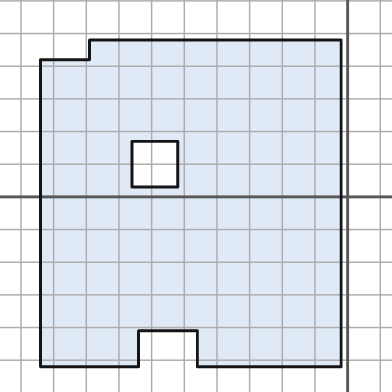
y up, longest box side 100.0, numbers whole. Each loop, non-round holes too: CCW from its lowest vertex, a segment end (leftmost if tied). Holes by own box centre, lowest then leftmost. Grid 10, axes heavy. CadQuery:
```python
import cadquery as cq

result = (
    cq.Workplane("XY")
    .moveTo(-94.0, -52.0)
    .lineTo(-64.0, -52.0)
    .lineTo(-64.0, -41.0)
    .lineTo(-46.0, -41.0)
    .lineTo(-46.0, -52.0)
    .lineTo(-2.0, -52.0)
    .lineTo(-2.0, 48.0)
    .lineTo(-79.0, 48.0)
    .lineTo(-79.0, 42.0)
    .lineTo(-94.0, 42.0)
    .close()
    .moveTo(-66.0, 3.0)
    .lineTo(-52.0, 3.0)
    .lineTo(-52.0, 17.0)
    .lineTo(-66.0, 17.0)
    .close()
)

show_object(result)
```